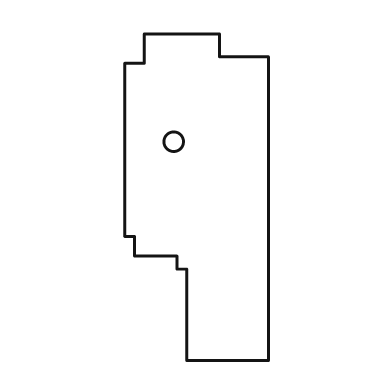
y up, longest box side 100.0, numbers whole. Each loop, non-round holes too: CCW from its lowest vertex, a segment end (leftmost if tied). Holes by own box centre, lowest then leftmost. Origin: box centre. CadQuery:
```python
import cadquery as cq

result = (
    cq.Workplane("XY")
    .moveTo(-3.0, -50.0)
    .lineTo(22.0, -50.0)
    .lineTo(22.0, 43.0)
    .lineTo(7.0, 43.0)
    .lineTo(7.0, 50.0)
    .lineTo(-16.0, 50.0)
    .lineTo(-16.0, 41.0)
    .lineTo(-22.0, 41.0)
    .lineTo(-22.0, -12.0)
    .lineTo(-19.0, -12.0)
    .lineTo(-19.0, -18.0)
    .lineTo(-6.0, -18.0)
    .lineTo(-6.0, -22.0)
    .lineTo(-3.0, -22.0)
    .close()
    .moveTo(-7.0, 17.0)
    .circle(3.0)
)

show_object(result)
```